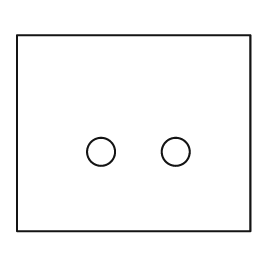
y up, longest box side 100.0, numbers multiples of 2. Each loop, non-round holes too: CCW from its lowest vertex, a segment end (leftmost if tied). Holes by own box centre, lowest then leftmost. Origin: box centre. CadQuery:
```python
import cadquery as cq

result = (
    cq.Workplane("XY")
    .moveTo(-50.0, -42.0)
    .lineTo(50.0, -42.0)
    .lineTo(50.0, 42.0)
    .lineTo(-50.0, 42.0)
    .close()
    .moveTo(-14.0, -8.0)
    .circle(6.0)
    .moveTo(18.0, -8.0)
    .circle(6.0)
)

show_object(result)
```